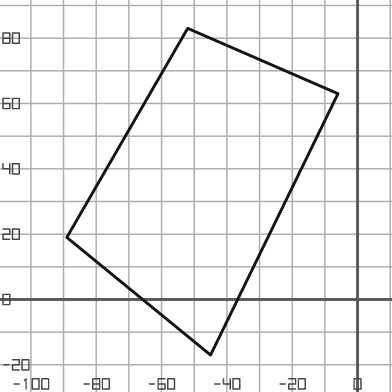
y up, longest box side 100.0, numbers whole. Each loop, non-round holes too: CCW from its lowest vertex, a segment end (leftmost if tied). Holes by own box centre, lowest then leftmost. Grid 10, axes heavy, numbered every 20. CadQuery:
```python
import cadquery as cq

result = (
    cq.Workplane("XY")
    .moveTo(-45.0, -17.0)
    .lineTo(-6.0, 63.0)
    .lineTo(-52.0, 83.0)
    .lineTo(-89.0, 19.0)
    .close()
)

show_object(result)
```